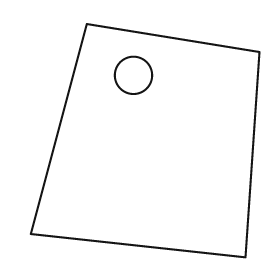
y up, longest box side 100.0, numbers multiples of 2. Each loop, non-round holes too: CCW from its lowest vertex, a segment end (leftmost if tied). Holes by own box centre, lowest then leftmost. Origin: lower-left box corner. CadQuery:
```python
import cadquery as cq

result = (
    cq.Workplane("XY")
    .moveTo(92.0, 0.0)
    .lineTo(98.0, 88.0)
    .lineTo(24.0, 100.0)
    .lineTo(0.0, 10.0)
    .close()
    .moveTo(44.0, 78.0)
    .circle(8.0)
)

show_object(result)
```